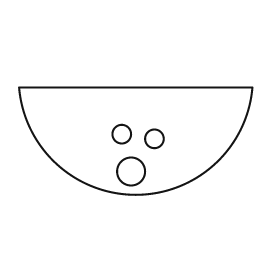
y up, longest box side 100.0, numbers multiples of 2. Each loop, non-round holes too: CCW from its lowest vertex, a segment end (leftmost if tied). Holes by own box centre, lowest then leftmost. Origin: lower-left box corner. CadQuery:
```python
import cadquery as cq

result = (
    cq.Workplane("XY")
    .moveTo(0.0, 46.0)
    .threePointArc((50.0, 0.0), (100.0, 46.0))
    .close()
    .moveTo(48.0, 10.0)
    .circle(6.0)
    .moveTo(58.0, 24.0)
    .circle(4.0)
    .moveTo(44.0, 26.0)
    .circle(4.0)
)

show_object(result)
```